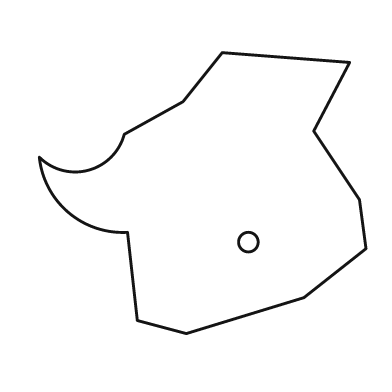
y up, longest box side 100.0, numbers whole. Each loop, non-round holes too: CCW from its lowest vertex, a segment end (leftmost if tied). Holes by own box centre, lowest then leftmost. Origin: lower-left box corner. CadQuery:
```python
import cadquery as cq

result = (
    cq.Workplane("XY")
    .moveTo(45.0, 0.0)
    .lineTo(81.0, 11.0)
    .lineTo(100.0, 26.0)
    .lineTo(98.0, 41.0)
    .lineTo(84.0, 62.0)
    .lineTo(95.0, 83.0)
    .lineTo(56.0, 86.0)
    .lineTo(44.0, 71.0)
    .lineTo(26.0, 61.0)
    .threePointArc((15.0, 50.0), (0.0, 54.0))
    .threePointArc((9.0, 37.0), (27.0, 31.0))
    .lineTo(30.0, 4.0)
    .close()
    .moveTo(64.0, 28.0)
    .circle(3.0)
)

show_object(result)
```